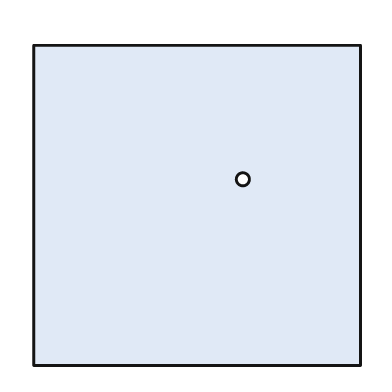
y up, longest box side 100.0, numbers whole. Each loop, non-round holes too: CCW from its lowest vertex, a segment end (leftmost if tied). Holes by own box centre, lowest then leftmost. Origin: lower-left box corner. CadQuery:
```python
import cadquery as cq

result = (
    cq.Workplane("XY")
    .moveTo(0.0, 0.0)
    .lineTo(100.0, 0.0)
    .lineTo(100.0, 98.0)
    .lineTo(0.0, 98.0)
    .close()
    .moveTo(64.0, 57.0)
    .circle(2.0)
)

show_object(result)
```